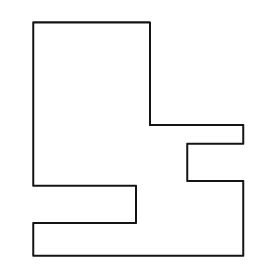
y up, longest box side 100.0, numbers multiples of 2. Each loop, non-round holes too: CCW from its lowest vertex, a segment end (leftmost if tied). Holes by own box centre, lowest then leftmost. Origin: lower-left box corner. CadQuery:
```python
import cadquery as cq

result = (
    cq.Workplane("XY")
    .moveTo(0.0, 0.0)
    .lineTo(90.0, 0.0)
    .lineTo(90.0, 32.0)
    .lineTo(66.0, 32.0)
    .lineTo(66.0, 48.0)
    .lineTo(90.0, 48.0)
    .lineTo(90.0, 56.0)
    .lineTo(50.0, 56.0)
    .lineTo(50.0, 100.0)
    .lineTo(0.0, 100.0)
    .lineTo(0.0, 30.0)
    .lineTo(44.0, 30.0)
    .lineTo(44.0, 14.0)
    .lineTo(0.0, 14.0)
    .close()
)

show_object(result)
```